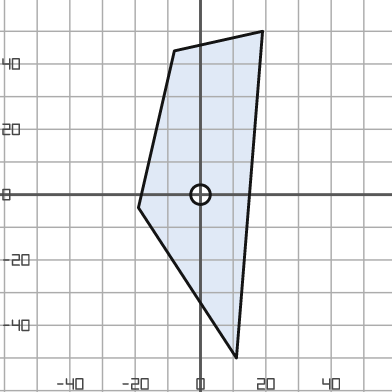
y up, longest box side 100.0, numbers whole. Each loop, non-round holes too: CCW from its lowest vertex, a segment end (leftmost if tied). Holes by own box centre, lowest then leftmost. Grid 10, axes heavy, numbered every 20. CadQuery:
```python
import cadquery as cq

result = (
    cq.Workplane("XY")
    .moveTo(11.0, -50.0)
    .lineTo(19.0, 50.0)
    .lineTo(-8.0, 44.0)
    .lineTo(-19.0, -4.0)
    .close()
    .moveTo(0.0, 0.0)
    .circle(3.0)
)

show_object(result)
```